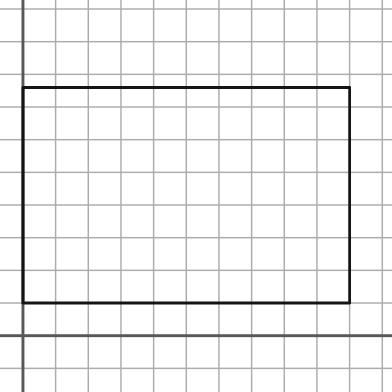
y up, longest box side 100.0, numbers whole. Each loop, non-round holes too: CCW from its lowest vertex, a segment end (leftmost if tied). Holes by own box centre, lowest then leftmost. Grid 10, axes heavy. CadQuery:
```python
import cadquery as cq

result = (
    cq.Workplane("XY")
    .moveTo(0.0, 10.0)
    .lineTo(100.0, 10.0)
    .lineTo(100.0, 76.0)
    .lineTo(0.0, 76.0)
    .close()
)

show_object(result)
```